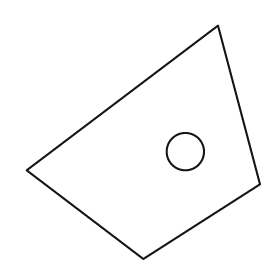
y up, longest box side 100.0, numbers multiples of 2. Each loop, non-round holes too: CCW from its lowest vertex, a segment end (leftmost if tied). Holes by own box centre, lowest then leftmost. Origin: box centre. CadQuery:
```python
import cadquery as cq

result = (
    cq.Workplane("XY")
    .moveTo(0.0, -50.0)
    .lineTo(50.0, -18.0)
    .lineTo(32.0, 50.0)
    .lineTo(-50.0, -12.0)
    .close()
    .moveTo(18.0, -4.0)
    .circle(8.0)
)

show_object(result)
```